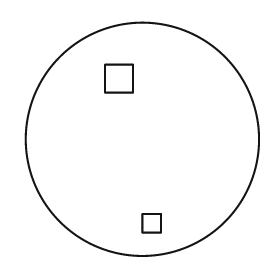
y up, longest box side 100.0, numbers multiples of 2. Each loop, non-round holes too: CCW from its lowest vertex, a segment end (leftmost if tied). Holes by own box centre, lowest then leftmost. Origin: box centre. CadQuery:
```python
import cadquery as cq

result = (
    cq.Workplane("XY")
    .moveTo(0.0, 0.0)
    .circle(50.0)
    .moveTo(0.0, -40.0)
    .lineTo(8.0, -40.0)
    .lineTo(8.0, -32.0)
    .lineTo(0.0, -32.0)
    .close()
    .moveTo(-16.0, 20.0)
    .lineTo(-4.0, 20.0)
    .lineTo(-4.0, 32.0)
    .lineTo(-16.0, 32.0)
    .close()
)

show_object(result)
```